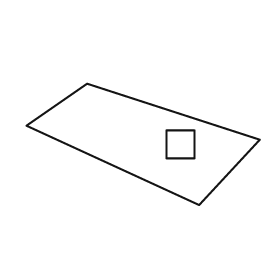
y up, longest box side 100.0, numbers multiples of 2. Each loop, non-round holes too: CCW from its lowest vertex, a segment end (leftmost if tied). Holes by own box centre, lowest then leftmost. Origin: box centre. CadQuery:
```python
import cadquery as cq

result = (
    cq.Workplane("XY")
    .moveTo(24.0, -26.0)
    .lineTo(50.0, 2.0)
    .lineTo(-24.0, 26.0)
    .lineTo(-50.0, 8.0)
    .close()
    .moveTo(10.0, -6.0)
    .lineTo(22.0, -6.0)
    .lineTo(22.0, 6.0)
    .lineTo(10.0, 6.0)
    .close()
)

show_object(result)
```